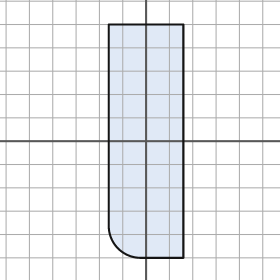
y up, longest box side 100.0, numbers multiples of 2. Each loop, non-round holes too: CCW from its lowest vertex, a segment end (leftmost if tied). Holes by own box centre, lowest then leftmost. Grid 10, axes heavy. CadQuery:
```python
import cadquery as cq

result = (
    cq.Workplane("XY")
    .moveTo(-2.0, -50.0)
    .lineTo(16.0, -50.0)
    .lineTo(16.0, 50.0)
    .lineTo(-16.0, 50.0)
    .lineTo(-16.0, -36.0)
    .threePointArc((-12.0, -46.0), (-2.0, -50.0))
    .close()
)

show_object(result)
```